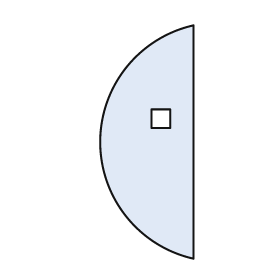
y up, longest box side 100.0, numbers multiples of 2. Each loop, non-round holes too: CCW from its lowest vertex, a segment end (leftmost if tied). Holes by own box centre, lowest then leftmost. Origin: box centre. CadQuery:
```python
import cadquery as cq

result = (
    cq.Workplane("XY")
    .moveTo(20.0, -50.0)
    .lineTo(20.0, 50.0)
    .threePointArc((-20.0, 0.0), (20.0, -50.0))
    .close()
    .moveTo(2.0, 6.0)
    .lineTo(10.0, 6.0)
    .lineTo(10.0, 14.0)
    .lineTo(2.0, 14.0)
    .close()
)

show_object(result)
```